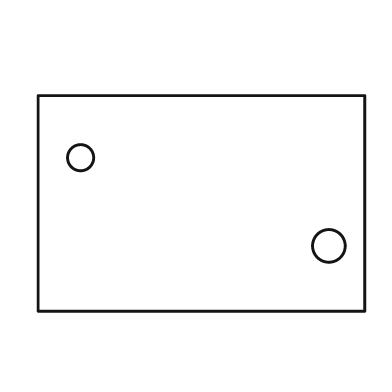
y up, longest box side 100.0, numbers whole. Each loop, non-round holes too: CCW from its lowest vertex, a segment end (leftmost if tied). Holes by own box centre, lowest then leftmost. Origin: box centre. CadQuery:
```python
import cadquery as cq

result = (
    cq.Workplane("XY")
    .moveTo(-50.0, -33.0)
    .lineTo(50.0, -33.0)
    .lineTo(50.0, 33.0)
    .lineTo(-50.0, 33.0)
    .close()
    .moveTo(39.0, -13.0)
    .circle(5.0)
    .moveTo(-37.0, 14.0)
    .circle(4.0)
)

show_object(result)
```